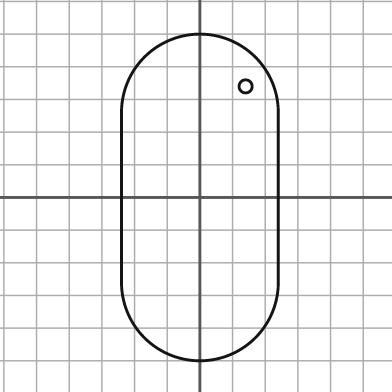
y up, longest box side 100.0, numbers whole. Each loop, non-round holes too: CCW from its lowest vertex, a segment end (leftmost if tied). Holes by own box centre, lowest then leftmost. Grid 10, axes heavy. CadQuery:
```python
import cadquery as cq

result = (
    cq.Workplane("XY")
    .moveTo(-24.0, -26.0)
    .threePointArc((0.0, -50.0), (24.0, -26.0))
    .lineTo(24.0, 26.0)
    .threePointArc((0.0, 50.0), (-24.0, 26.0))
    .close()
    .moveTo(14.0, 34.0)
    .circle(2.0)
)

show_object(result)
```